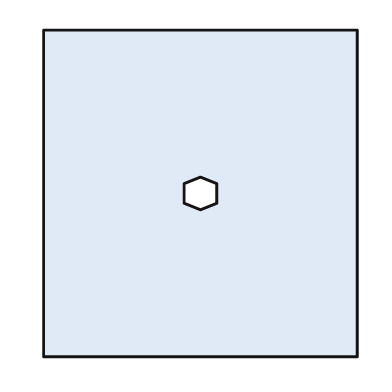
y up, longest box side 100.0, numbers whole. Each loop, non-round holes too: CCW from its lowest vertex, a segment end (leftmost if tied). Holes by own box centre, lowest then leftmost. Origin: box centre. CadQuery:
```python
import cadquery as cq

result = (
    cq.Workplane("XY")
    .moveTo(-48.0, -50.0)
    .lineTo(48.0, -50.0)
    .lineTo(48.0, 50.0)
    .lineTo(-48.0, 50.0)
    .close()
    .moveTo(0.0, -5.0)
    .lineTo(5.0, -3.0)
    .lineTo(5.0, 3.0)
    .lineTo(0.0, 5.0)
    .lineTo(-5.0, 3.0)
    .lineTo(-5.0, -3.0)
    .close()
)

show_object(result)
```